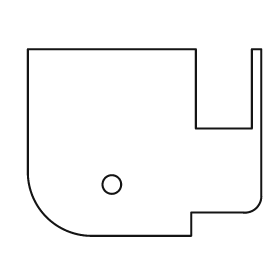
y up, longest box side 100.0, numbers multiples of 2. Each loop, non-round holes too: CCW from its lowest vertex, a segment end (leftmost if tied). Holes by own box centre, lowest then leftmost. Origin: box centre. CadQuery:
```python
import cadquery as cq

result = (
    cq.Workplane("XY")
    .moveTo(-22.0, -40.0)
    .lineTo(20.0, -40.0)
    .lineTo(20.0, -30.0)
    .lineTo(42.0, -30.0)
    .threePointArc((48.0, -28.0), (50.0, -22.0))
    .lineTo(50.0, 40.0)
    .lineTo(46.0, 40.0)
    .lineTo(46.0, 6.0)
    .lineTo(22.0, 6.0)
    .lineTo(22.0, 40.0)
    .lineTo(-50.0, 40.0)
    .lineTo(-50.0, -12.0)
    .threePointArc((-42.0, -32.0), (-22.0, -40.0))
    .close()
    .moveTo(-14.0, -18.0)
    .circle(4.0)
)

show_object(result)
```